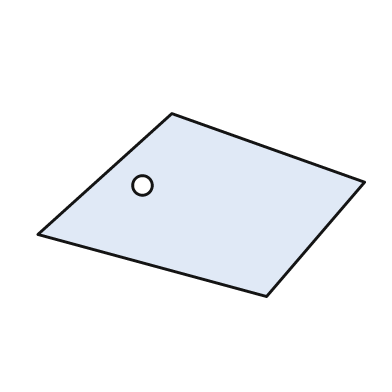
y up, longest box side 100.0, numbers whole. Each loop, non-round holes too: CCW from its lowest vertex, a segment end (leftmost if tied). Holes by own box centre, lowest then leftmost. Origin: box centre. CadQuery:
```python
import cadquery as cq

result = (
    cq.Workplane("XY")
    .moveTo(20.0, -28.0)
    .lineTo(50.0, 7.0)
    .lineTo(-9.0, 28.0)
    .lineTo(-50.0, -9.0)
    .close()
    .moveTo(-18.0, 6.0)
    .circle(3.0)
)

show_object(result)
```